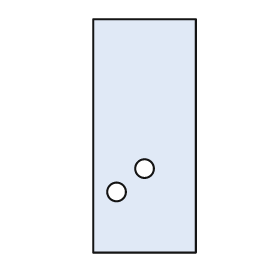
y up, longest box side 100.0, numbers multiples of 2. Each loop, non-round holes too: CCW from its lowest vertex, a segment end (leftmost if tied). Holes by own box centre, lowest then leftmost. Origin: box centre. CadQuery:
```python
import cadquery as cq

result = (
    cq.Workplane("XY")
    .moveTo(-22.0, -50.0)
    .lineTo(22.0, -50.0)
    .lineTo(22.0, 50.0)
    .lineTo(-22.0, 50.0)
    .close()
    .moveTo(-12.0, -24.0)
    .circle(4.0)
    .moveTo(0.0, -14.0)
    .circle(4.0)
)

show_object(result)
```